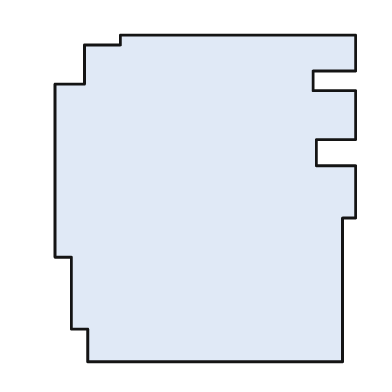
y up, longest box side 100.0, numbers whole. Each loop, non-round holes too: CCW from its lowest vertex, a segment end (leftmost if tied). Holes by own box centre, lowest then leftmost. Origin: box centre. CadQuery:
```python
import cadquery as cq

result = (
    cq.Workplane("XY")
    .moveTo(-36.0, -50.0)
    .lineTo(42.0, -50.0)
    .lineTo(42.0, -6.0)
    .lineTo(46.0, -6.0)
    .lineTo(46.0, 10.0)
    .lineTo(34.0, 10.0)
    .lineTo(34.0, 18.0)
    .lineTo(46.0, 18.0)
    .lineTo(46.0, 33.0)
    .lineTo(33.0, 33.0)
    .lineTo(33.0, 39.0)
    .lineTo(46.0, 39.0)
    .lineTo(46.0, 50.0)
    .lineTo(-26.0, 50.0)
    .lineTo(-26.0, 47.0)
    .lineTo(-37.0, 47.0)
    .lineTo(-37.0, 35.0)
    .lineTo(-46.0, 35.0)
    .lineTo(-46.0, -18.0)
    .lineTo(-41.0, -18.0)
    .lineTo(-41.0, -40.0)
    .lineTo(-36.0, -40.0)
    .close()
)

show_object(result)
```